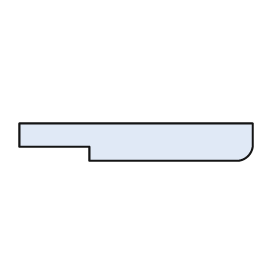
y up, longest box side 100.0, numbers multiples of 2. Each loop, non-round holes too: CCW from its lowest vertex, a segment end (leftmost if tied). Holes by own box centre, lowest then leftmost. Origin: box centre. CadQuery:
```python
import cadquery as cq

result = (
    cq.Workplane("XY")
    .moveTo(-20.0, -8.0)
    .lineTo(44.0, -8.0)
    .threePointArc((48.0, -6.0), (50.0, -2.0))
    .lineTo(50.0, 8.0)
    .lineTo(-50.0, 8.0)
    .lineTo(-50.0, -2.0)
    .lineTo(-20.0, -2.0)
    .close()
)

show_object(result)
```